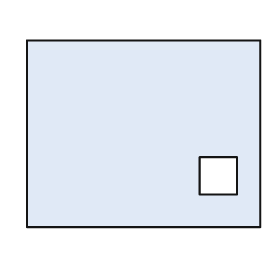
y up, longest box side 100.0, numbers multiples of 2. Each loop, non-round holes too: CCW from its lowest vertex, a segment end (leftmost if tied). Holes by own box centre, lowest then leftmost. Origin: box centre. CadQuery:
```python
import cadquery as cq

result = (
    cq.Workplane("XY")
    .moveTo(-50.0, -40.0)
    .lineTo(50.0, -40.0)
    .lineTo(50.0, 40.0)
    .lineTo(-50.0, 40.0)
    .close()
    .moveTo(24.0, -26.0)
    .lineTo(40.0, -26.0)
    .lineTo(40.0, -10.0)
    .lineTo(24.0, -10.0)
    .close()
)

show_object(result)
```